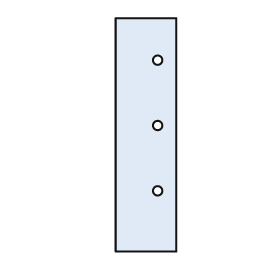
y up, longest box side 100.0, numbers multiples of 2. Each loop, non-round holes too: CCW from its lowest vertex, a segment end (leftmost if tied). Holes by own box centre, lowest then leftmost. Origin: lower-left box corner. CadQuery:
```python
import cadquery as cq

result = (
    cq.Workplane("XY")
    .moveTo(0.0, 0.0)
    .lineTo(26.0, 0.0)
    .lineTo(26.0, 100.0)
    .lineTo(0.0, 100.0)
    .close()
    .moveTo(18.0, 26.0)
    .circle(2.0)
    .moveTo(18.0, 54.0)
    .circle(2.0)
    .moveTo(18.0, 82.0)
    .circle(2.0)
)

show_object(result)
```